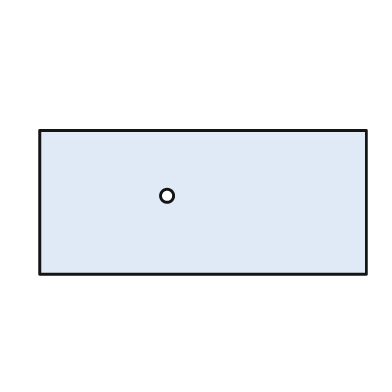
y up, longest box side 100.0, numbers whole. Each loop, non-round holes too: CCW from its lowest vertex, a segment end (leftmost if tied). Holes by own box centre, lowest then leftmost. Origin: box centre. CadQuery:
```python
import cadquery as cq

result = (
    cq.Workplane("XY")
    .moveTo(-50.0, -22.0)
    .lineTo(50.0, -22.0)
    .lineTo(50.0, 22.0)
    .lineTo(-50.0, 22.0)
    .close()
    .moveTo(-11.0, 2.0)
    .circle(2.0)
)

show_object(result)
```